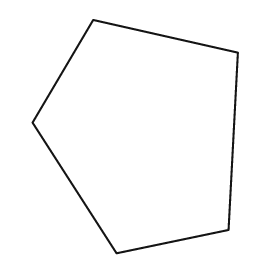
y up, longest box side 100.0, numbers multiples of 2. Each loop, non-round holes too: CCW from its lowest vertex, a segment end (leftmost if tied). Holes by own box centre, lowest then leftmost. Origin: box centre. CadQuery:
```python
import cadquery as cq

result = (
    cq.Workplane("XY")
    .moveTo(-8.0, -50.0)
    .lineTo(40.0, -40.0)
    .lineTo(44.0, 36.0)
    .lineTo(-18.0, 50.0)
    .lineTo(-44.0, 6.0)
    .close()
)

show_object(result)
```